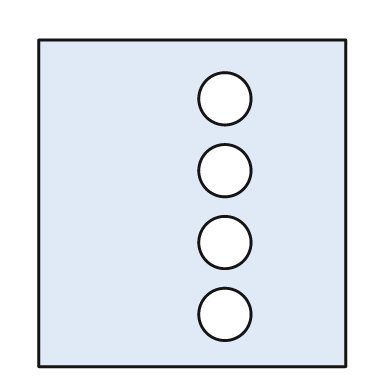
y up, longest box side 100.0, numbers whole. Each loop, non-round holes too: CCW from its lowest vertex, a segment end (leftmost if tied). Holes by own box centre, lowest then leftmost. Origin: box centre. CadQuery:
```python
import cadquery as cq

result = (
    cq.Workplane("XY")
    .moveTo(-47.0, -50.0)
    .lineTo(47.0, -50.0)
    .lineTo(47.0, 50.0)
    .lineTo(-47.0, 50.0)
    .close()
    .moveTo(10.0, -34.0)
    .circle(8.0)
    .moveTo(10.0, -12.0)
    .circle(8.0)
    .moveTo(10.0, 10.0)
    .circle(8.0)
    .moveTo(10.0, 32.0)
    .circle(8.0)
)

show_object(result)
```